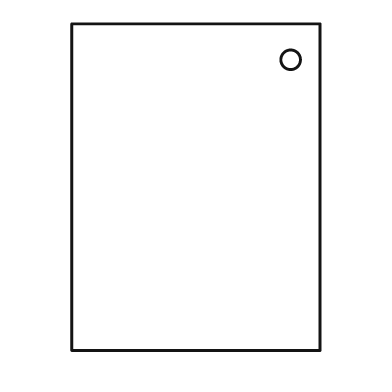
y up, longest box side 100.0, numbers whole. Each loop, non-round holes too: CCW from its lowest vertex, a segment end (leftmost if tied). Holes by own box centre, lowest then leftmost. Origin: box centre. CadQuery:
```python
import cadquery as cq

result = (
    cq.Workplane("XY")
    .moveTo(-38.0, -50.0)
    .lineTo(38.0, -50.0)
    .lineTo(38.0, 50.0)
    .lineTo(-38.0, 50.0)
    .close()
    .moveTo(29.0, 39.0)
    .circle(3.0)
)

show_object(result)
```